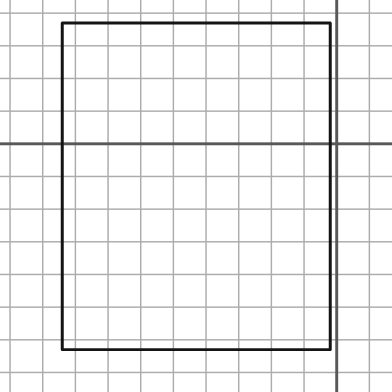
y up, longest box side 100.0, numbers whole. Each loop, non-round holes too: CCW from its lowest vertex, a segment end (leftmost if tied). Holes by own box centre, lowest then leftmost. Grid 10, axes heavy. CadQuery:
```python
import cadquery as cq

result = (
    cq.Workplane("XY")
    .moveTo(-84.0, -63.0)
    .lineTo(-2.0, -63.0)
    .lineTo(-2.0, 37.0)
    .lineTo(-84.0, 37.0)
    .close()
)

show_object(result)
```